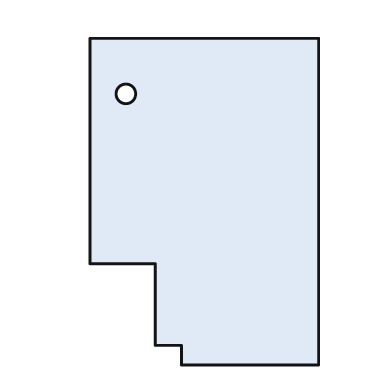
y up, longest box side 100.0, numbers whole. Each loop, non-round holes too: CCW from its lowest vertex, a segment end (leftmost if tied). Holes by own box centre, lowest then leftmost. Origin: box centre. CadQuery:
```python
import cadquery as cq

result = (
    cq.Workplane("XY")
    .moveTo(-7.0, -50.0)
    .lineTo(35.0, -50.0)
    .lineTo(35.0, 50.0)
    .lineTo(-35.0, 50.0)
    .lineTo(-35.0, -19.0)
    .lineTo(-15.0, -19.0)
    .lineTo(-15.0, -44.0)
    .lineTo(-7.0, -44.0)
    .close()
    .moveTo(-24.0, 33.0)
    .circle(3.0)
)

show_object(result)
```